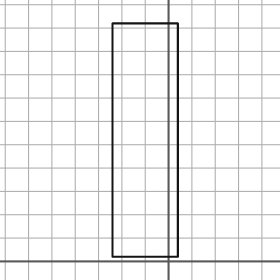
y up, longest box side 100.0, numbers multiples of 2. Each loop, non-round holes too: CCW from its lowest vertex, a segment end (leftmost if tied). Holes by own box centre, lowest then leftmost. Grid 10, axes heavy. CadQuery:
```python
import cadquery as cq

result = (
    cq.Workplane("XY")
    .moveTo(-24.0, 2.0)
    .lineTo(4.0, 2.0)
    .lineTo(4.0, 102.0)
    .lineTo(-24.0, 102.0)
    .close()
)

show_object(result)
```